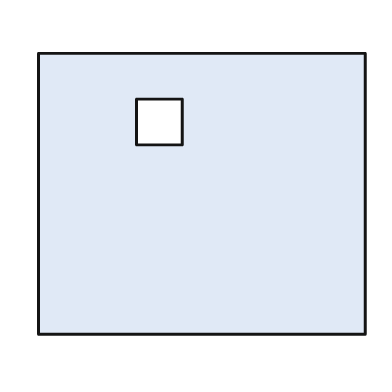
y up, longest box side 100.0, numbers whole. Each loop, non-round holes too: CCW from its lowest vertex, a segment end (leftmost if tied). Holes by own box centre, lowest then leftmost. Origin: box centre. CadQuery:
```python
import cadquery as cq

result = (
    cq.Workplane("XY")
    .moveTo(-50.0, -43.0)
    .lineTo(50.0, -43.0)
    .lineTo(50.0, 43.0)
    .lineTo(-50.0, 43.0)
    .close()
    .moveTo(-20.0, 15.0)
    .lineTo(-6.0, 15.0)
    .lineTo(-6.0, 29.0)
    .lineTo(-20.0, 29.0)
    .close()
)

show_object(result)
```